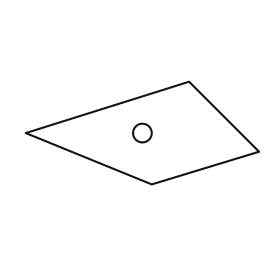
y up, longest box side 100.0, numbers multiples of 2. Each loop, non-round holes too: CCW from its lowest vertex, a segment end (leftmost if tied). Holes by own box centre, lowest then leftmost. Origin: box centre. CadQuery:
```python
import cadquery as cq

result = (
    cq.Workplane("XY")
    .moveTo(4.0, -22.0)
    .lineTo(50.0, -8.0)
    .lineTo(20.0, 22.0)
    .lineTo(-50.0, 0.0)
    .close()
    .moveTo(0.0, 0.0)
    .circle(4.0)
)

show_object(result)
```